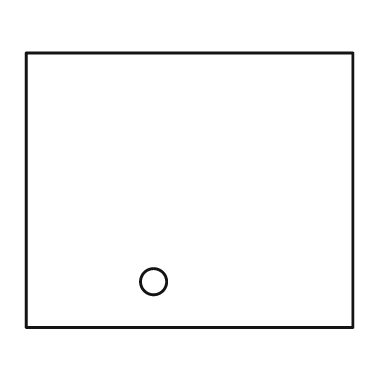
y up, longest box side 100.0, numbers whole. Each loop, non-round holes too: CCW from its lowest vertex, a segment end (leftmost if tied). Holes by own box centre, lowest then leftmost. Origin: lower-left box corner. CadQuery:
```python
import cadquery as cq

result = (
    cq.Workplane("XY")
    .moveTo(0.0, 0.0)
    .lineTo(100.0, 0.0)
    .lineTo(100.0, 84.0)
    .lineTo(0.0, 84.0)
    .close()
    .moveTo(39.0, 14.0)
    .circle(4.0)
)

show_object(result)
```